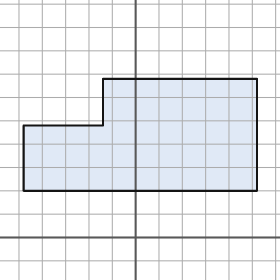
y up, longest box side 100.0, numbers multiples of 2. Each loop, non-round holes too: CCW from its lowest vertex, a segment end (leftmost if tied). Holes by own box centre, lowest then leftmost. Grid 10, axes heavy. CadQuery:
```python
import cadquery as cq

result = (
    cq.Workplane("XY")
    .moveTo(-48.0, 20.0)
    .lineTo(52.0, 20.0)
    .lineTo(52.0, 68.0)
    .lineTo(-14.0, 68.0)
    .lineTo(-14.0, 48.0)
    .lineTo(-48.0, 48.0)
    .close()
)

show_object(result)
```